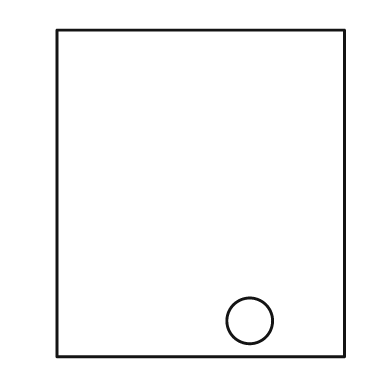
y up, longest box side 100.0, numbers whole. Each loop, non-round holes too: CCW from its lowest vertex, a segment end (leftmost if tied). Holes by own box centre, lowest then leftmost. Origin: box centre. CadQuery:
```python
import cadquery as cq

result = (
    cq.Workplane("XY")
    .moveTo(-44.0, -50.0)
    .lineTo(44.0, -50.0)
    .lineTo(44.0, 50.0)
    .lineTo(-44.0, 50.0)
    .close()
    .moveTo(15.0, -39.0)
    .circle(7.0)
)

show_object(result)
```